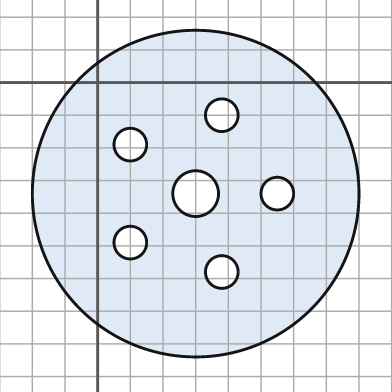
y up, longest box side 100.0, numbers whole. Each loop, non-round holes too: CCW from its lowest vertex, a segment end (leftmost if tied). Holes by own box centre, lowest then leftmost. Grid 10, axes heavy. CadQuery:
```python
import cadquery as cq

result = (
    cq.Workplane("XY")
    .moveTo(30.0, -34.0)
    .circle(50.0)
    .moveTo(38.0, -58.0)
    .circle(5.0)
    .moveTo(10.0, -49.0)
    .circle(5.0)
    .moveTo(30.0, -34.0)
    .circle(7.0)
    .moveTo(55.0, -34.0)
    .circle(5.0)
    .moveTo(10.0, -19.0)
    .circle(5.0)
    .moveTo(38.0, -10.0)
    .circle(5.0)
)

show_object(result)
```